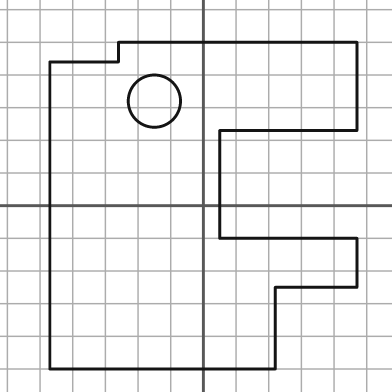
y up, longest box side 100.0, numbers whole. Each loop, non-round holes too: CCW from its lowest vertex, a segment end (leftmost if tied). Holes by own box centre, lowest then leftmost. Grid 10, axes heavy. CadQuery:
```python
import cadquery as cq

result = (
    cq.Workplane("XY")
    .moveTo(-47.0, -50.0)
    .lineTo(22.0, -50.0)
    .lineTo(22.0, -25.0)
    .lineTo(47.0, -25.0)
    .lineTo(47.0, -10.0)
    .lineTo(5.0, -10.0)
    .lineTo(5.0, 23.0)
    .lineTo(47.0, 23.0)
    .lineTo(47.0, 50.0)
    .lineTo(-26.0, 50.0)
    .lineTo(-26.0, 44.0)
    .lineTo(-47.0, 44.0)
    .close()
    .moveTo(-15.0, 32.0)
    .circle(8.0)
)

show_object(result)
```